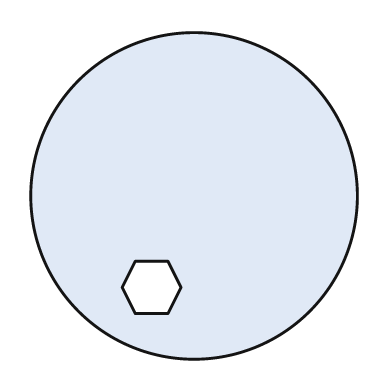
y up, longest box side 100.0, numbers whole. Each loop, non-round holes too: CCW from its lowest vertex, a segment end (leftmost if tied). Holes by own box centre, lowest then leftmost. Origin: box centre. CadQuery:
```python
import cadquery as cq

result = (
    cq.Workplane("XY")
    .moveTo(0.0, 0.0)
    .circle(50.0)
    .moveTo(-18.0, -36.0)
    .lineTo(-8.0, -36.0)
    .lineTo(-4.0, -28.0)
    .lineTo(-8.0, -20.0)
    .lineTo(-18.0, -20.0)
    .lineTo(-22.0, -28.0)
    .close()
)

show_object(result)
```